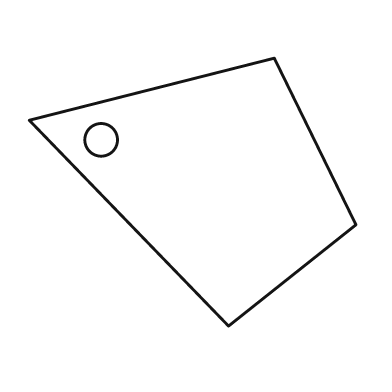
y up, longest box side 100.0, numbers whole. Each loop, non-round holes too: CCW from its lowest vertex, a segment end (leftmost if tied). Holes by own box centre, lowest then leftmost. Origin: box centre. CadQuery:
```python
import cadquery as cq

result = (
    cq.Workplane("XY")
    .moveTo(11.0, -41.0)
    .lineTo(50.0, -10.0)
    .lineTo(25.0, 41.0)
    .lineTo(-50.0, 22.0)
    .close()
    .moveTo(-28.0, 16.0)
    .circle(5.0)
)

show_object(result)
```